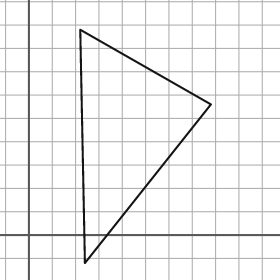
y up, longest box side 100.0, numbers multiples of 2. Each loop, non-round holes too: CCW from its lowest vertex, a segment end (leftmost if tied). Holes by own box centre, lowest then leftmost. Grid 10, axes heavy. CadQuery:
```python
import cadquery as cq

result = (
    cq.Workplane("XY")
    .moveTo(24.0, -12.0)
    .lineTo(78.0, 56.0)
    .lineTo(22.0, 88.0)
    .close()
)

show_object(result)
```